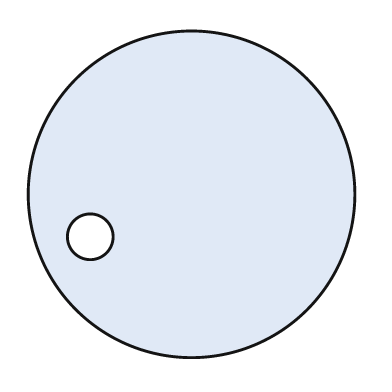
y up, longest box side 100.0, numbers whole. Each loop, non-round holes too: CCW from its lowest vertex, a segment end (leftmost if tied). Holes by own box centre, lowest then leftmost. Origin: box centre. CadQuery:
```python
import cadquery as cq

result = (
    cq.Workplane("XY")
    .moveTo(0.0, 0.0)
    .circle(50.0)
    .moveTo(-31.0, -13.0)
    .circle(7.0)
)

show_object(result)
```